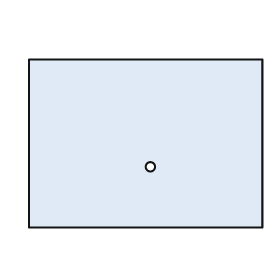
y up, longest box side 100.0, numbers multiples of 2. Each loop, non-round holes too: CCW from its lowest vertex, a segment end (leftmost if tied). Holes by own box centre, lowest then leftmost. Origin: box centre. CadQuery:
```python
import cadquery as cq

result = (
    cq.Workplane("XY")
    .moveTo(-50.0, -36.0)
    .lineTo(50.0, -36.0)
    .lineTo(50.0, 36.0)
    .lineTo(-50.0, 36.0)
    .close()
    .moveTo(2.0, -10.0)
    .circle(2.0)
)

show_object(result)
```